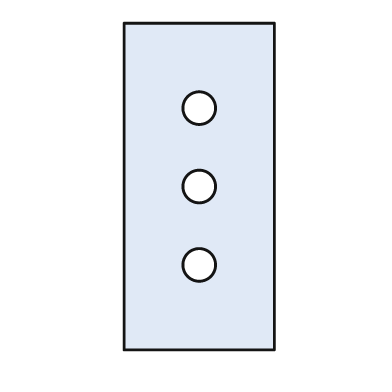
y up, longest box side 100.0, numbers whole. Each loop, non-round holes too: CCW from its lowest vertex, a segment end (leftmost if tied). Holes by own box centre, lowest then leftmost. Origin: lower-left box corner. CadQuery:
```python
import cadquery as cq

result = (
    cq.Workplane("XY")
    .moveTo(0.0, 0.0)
    .lineTo(46.0, 0.0)
    .lineTo(46.0, 100.0)
    .lineTo(0.0, 100.0)
    .close()
    .moveTo(23.0, 26.0)
    .circle(5.0)
    .moveTo(23.0, 50.0)
    .circle(5.0)
    .moveTo(23.0, 74.0)
    .circle(5.0)
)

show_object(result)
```